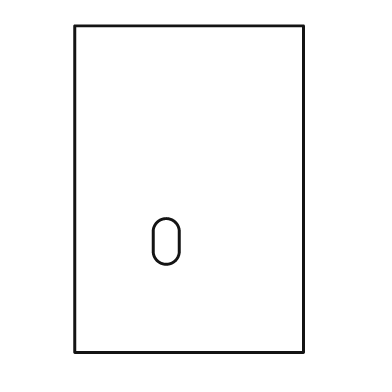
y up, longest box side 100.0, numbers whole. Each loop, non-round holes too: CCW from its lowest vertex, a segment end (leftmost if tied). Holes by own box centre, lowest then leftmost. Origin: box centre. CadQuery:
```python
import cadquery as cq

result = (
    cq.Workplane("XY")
    .moveTo(-35.0, -50.0)
    .lineTo(35.0, -50.0)
    .lineTo(35.0, 50.0)
    .lineTo(-35.0, 50.0)
    .close()
    .moveTo(-11.0, -19.0)
    .threePointArc((-7.0, -23.0), (-3.0, -19.0))
    .lineTo(-3.0, -13.0)
    .threePointArc((-7.0, -9.0), (-11.0, -13.0))
    .close()
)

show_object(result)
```